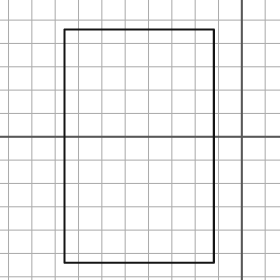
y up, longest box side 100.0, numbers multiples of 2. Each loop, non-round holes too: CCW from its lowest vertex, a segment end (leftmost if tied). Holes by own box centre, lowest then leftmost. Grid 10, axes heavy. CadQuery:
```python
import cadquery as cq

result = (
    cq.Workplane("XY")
    .moveTo(-76.0, -54.0)
    .lineTo(-12.0, -54.0)
    .lineTo(-12.0, 46.0)
    .lineTo(-76.0, 46.0)
    .close()
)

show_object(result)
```